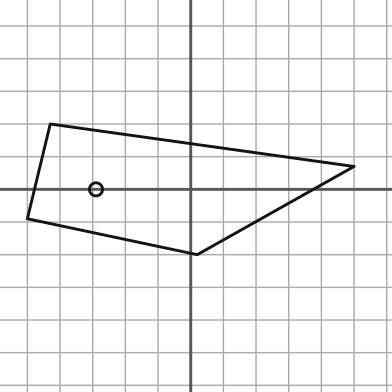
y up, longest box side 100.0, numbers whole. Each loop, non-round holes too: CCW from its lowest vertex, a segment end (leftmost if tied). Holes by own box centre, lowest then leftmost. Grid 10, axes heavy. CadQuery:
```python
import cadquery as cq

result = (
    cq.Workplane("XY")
    .moveTo(2.0, -20.0)
    .lineTo(50.0, 7.0)
    .lineTo(-43.0, 20.0)
    .lineTo(-50.0, -9.0)
    .close()
    .moveTo(-29.0, 0.0)
    .circle(2.0)
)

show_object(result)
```